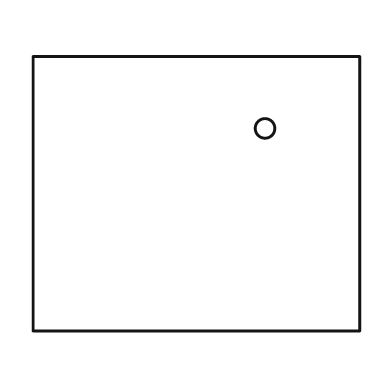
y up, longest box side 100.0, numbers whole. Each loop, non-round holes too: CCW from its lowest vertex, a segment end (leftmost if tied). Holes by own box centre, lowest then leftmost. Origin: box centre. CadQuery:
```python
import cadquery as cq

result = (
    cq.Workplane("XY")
    .moveTo(-50.0, -42.0)
    .lineTo(50.0, -42.0)
    .lineTo(50.0, 42.0)
    .lineTo(-50.0, 42.0)
    .close()
    .moveTo(21.0, 20.0)
    .circle(3.0)
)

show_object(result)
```